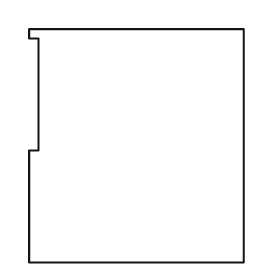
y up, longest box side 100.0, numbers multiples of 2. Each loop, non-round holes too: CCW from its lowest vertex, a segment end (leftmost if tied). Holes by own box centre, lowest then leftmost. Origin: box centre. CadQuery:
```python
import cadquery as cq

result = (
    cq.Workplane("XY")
    .moveTo(-46.0, -50.0)
    .lineTo(46.0, -50.0)
    .lineTo(46.0, 50.0)
    .lineTo(-46.0, 50.0)
    .lineTo(-46.0, 46.0)
    .lineTo(-42.0, 46.0)
    .lineTo(-42.0, -2.0)
    .lineTo(-46.0, -2.0)
    .close()
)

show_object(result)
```